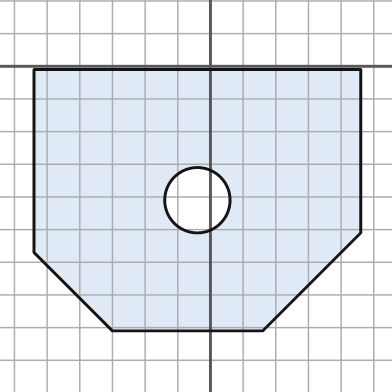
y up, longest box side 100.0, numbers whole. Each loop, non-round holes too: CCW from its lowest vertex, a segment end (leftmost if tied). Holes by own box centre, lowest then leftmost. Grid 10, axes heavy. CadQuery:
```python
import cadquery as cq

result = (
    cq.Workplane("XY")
    .moveTo(-30.0, -81.0)
    .lineTo(16.0, -81.0)
    .lineTo(46.0, -51.0)
    .lineTo(46.0, -1.0)
    .lineTo(-54.0, -1.0)
    .lineTo(-54.0, -57.0)
    .close()
    .moveTo(-4.0, -41.0)
    .circle(10.0)
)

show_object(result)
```